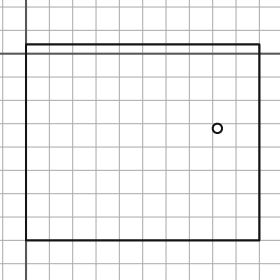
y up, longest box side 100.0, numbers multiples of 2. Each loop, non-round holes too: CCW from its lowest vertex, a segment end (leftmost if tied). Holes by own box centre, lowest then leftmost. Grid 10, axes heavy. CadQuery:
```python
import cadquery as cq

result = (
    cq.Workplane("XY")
    .moveTo(0.0, -80.0)
    .lineTo(100.0, -80.0)
    .lineTo(100.0, 4.0)
    .lineTo(0.0, 4.0)
    .close()
    .moveTo(82.0, -32.0)
    .circle(2.0)
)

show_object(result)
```